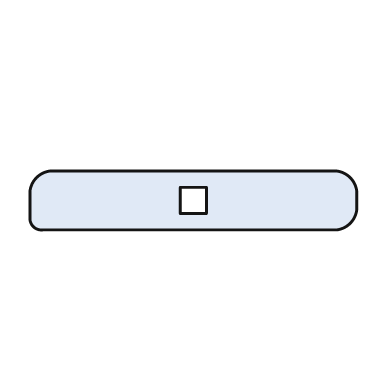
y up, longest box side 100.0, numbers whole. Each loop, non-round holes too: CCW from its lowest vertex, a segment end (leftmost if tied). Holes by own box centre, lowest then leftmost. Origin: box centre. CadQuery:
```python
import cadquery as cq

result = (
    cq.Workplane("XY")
    .moveTo(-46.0, -9.0)
    .lineTo(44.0, -9.0)
    .threePointArc((48.0, -7.0), (50.0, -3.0))
    .lineTo(50.0, 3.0)
    .threePointArc((48.0, 7.0), (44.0, 9.0))
    .lineTo(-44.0, 9.0)
    .threePointArc((-48.0, 7.0), (-50.0, 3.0))
    .lineTo(-50.0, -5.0)
    .threePointArc((-49.0, -8.0), (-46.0, -9.0))
    .close()
    .moveTo(-4.0, -4.0)
    .lineTo(4.0, -4.0)
    .lineTo(4.0, 4.0)
    .lineTo(-4.0, 4.0)
    .close()
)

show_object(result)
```